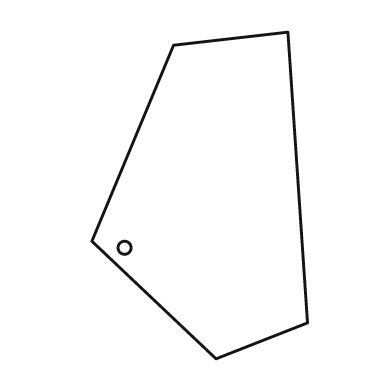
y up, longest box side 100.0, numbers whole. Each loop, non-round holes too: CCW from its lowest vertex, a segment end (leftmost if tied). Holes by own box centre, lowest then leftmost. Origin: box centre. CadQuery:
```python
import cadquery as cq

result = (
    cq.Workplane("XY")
    .moveTo(5.0, -50.0)
    .lineTo(33.0, -39.0)
    .lineTo(27.0, 50.0)
    .lineTo(-8.0, 46.0)
    .lineTo(-33.0, -14.0)
    .close()
    .moveTo(-23.0, -16.0)
    .circle(2.0)
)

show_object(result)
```